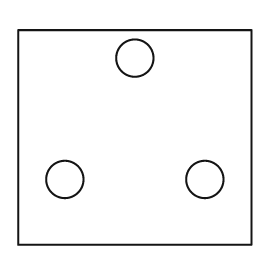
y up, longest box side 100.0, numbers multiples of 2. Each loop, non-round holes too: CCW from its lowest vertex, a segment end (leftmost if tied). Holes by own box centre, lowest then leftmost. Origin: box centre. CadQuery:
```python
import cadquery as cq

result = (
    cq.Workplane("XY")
    .moveTo(-50.0, -46.0)
    .lineTo(50.0, -46.0)
    .lineTo(50.0, 46.0)
    .lineTo(-50.0, 46.0)
    .close()
    .moveTo(-30.0, -18.0)
    .circle(8.0)
    .moveTo(30.0, -18.0)
    .circle(8.0)
    .moveTo(0.0, 34.0)
    .circle(8.0)
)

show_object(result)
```